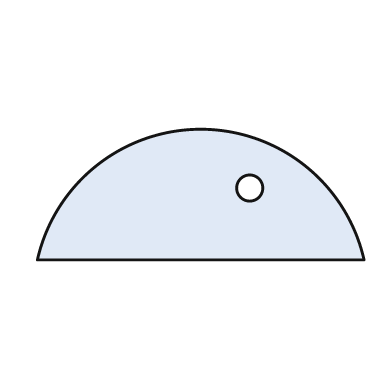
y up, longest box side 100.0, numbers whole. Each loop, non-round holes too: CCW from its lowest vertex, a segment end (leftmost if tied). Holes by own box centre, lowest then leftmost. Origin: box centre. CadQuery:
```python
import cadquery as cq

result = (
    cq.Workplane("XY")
    .moveTo(-50.0, -20.0)
    .lineTo(50.0, -20.0)
    .threePointArc((0.0, 20.0), (-50.0, -20.0))
    .close()
    .moveTo(15.0, 2.0)
    .circle(4.0)
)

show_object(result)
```